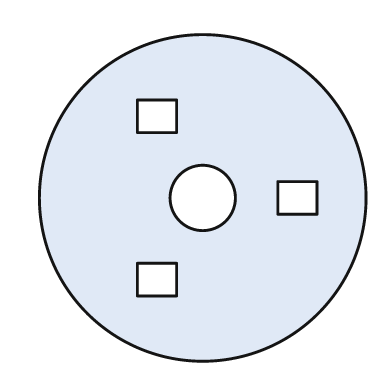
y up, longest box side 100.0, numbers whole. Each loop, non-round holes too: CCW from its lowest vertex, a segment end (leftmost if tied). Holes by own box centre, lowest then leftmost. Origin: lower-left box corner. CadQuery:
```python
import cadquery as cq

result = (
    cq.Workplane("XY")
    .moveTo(50.0, 50.0)
    .circle(50.0)
    .moveTo(30.0, 20.0)
    .lineTo(42.0, 20.0)
    .lineTo(42.0, 30.0)
    .lineTo(30.0, 30.0)
    .close()
    .moveTo(50.0, 50.0)
    .circle(10.0)
    .moveTo(73.0, 45.0)
    .lineTo(85.0, 45.0)
    .lineTo(85.0, 55.0)
    .lineTo(73.0, 55.0)
    .close()
    .moveTo(30.0, 70.0)
    .lineTo(42.0, 70.0)
    .lineTo(42.0, 80.0)
    .lineTo(30.0, 80.0)
    .close()
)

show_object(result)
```